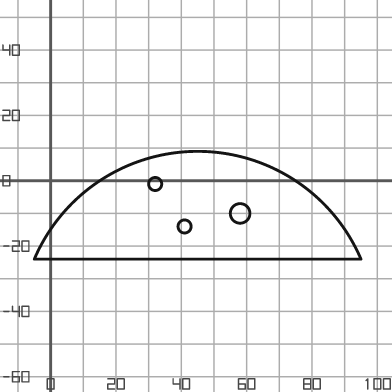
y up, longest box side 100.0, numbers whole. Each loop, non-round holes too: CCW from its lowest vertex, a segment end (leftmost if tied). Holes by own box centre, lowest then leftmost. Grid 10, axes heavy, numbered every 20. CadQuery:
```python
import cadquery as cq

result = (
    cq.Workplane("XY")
    .moveTo(-5.0, -24.0)
    .lineTo(95.0, -24.0)
    .threePointArc((45.0, 9.0), (-5.0, -24.0))
    .close()
    .moveTo(41.0, -14.0)
    .circle(2.0)
    .moveTo(58.0, -10.0)
    .circle(3.0)
    .moveTo(32.0, -1.0)
    .circle(2.0)
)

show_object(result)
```